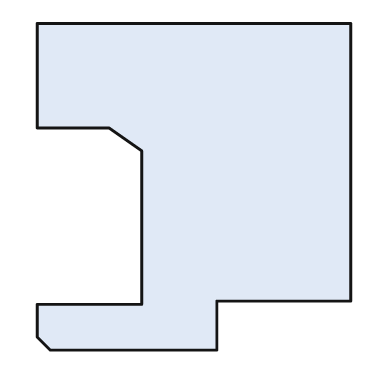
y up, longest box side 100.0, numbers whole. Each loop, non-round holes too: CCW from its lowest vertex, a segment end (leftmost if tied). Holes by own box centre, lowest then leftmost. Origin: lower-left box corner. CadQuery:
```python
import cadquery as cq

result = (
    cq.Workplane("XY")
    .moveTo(4.0, 0.0)
    .lineTo(55.0, 0.0)
    .lineTo(55.0, 15.0)
    .lineTo(96.0, 15.0)
    .lineTo(96.0, 100.0)
    .lineTo(0.0, 100.0)
    .lineTo(0.0, 68.0)
    .lineTo(22.0, 68.0)
    .lineTo(32.0, 61.0)
    .lineTo(32.0, 14.0)
    .lineTo(0.0, 14.0)
    .lineTo(0.0, 4.0)
    .close()
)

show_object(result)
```